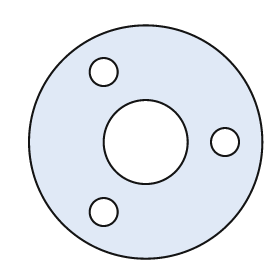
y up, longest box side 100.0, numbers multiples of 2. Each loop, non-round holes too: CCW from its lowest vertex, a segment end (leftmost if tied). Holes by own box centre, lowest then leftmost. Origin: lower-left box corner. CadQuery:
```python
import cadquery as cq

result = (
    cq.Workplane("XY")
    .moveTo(50.0, 50.0)
    .circle(50.0)
    .moveTo(32.0, 20.0)
    .circle(6.0)
    .moveTo(50.0, 50.0)
    .circle(18.0)
    .moveTo(84.0, 50.0)
    .circle(6.0)
    .moveTo(32.0, 80.0)
    .circle(6.0)
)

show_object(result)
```